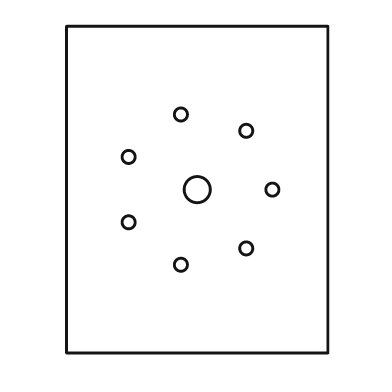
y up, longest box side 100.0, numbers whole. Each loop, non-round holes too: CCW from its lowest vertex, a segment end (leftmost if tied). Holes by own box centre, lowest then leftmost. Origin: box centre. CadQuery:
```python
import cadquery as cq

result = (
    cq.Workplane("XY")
    .moveTo(-40.0, -50.0)
    .lineTo(40.0, -50.0)
    .lineTo(40.0, 50.0)
    .lineTo(-40.0, 50.0)
    .close()
    .moveTo(-5.0, -23.0)
    .circle(2.0)
    .moveTo(15.0, -18.0)
    .circle(2.0)
    .moveTo(-21.0, -10.0)
    .circle(2.0)
    .moveTo(0.0, 0.0)
    .circle(4.0)
    .moveTo(23.0, 0.0)
    .circle(2.0)
    .moveTo(-21.0, 10.0)
    .circle(2.0)
    .moveTo(15.0, 18.0)
    .circle(2.0)
    .moveTo(-5.0, 23.0)
    .circle(2.0)
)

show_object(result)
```